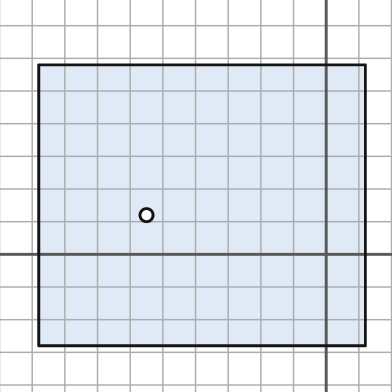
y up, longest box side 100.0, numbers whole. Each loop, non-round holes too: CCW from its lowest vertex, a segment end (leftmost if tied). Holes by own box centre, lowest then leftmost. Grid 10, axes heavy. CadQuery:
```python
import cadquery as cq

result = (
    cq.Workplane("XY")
    .moveTo(-88.0, -28.0)
    .lineTo(12.0, -28.0)
    .lineTo(12.0, 58.0)
    .lineTo(-88.0, 58.0)
    .close()
    .moveTo(-55.0, 12.0)
    .circle(2.0)
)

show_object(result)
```